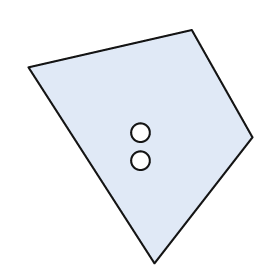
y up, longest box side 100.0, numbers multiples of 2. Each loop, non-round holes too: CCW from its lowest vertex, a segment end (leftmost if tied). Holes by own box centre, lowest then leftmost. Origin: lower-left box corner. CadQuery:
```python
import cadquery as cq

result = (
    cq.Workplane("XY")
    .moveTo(54.0, 0.0)
    .lineTo(96.0, 54.0)
    .lineTo(70.0, 100.0)
    .lineTo(0.0, 84.0)
    .close()
    .moveTo(48.0, 44.0)
    .circle(4.0)
    .moveTo(48.0, 56.0)
    .circle(4.0)
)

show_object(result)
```